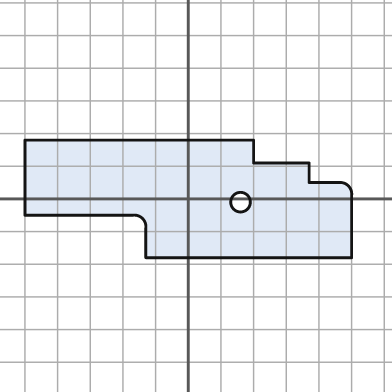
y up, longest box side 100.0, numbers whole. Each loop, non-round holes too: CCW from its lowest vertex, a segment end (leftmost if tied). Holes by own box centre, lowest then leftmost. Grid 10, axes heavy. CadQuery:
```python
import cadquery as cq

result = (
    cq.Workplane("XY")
    .moveTo(-13.0, -18.0)
    .lineTo(50.0, -18.0)
    .lineTo(50.0, 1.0)
    .threePointArc((49.0, 4.0), (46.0, 5.0))
    .lineTo(37.0, 5.0)
    .lineTo(37.0, 11.0)
    .lineTo(20.0, 11.0)
    .lineTo(20.0, 18.0)
    .lineTo(-50.0, 18.0)
    .lineTo(-50.0, -5.0)
    .lineTo(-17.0, -5.0)
    .threePointArc((-14.0, -6.0), (-13.0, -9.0))
    .close()
    .moveTo(16.0, -1.0)
    .circle(3.0)
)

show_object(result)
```